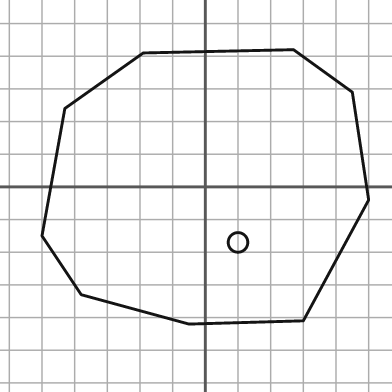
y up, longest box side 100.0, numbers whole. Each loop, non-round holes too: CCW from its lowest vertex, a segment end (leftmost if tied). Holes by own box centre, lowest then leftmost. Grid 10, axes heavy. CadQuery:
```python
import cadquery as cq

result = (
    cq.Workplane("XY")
    .moveTo(-5.0, -42.0)
    .lineTo(30.0, -41.0)
    .lineTo(50.0, -4.0)
    .lineTo(45.0, 29.0)
    .lineTo(27.0, 42.0)
    .lineTo(-19.0, 41.0)
    .lineTo(-43.0, 24.0)
    .lineTo(-50.0, -15.0)
    .lineTo(-38.0, -33.0)
    .close()
    .moveTo(10.0, -17.0)
    .circle(3.0)
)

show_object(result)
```